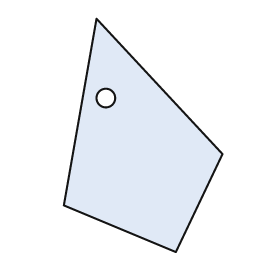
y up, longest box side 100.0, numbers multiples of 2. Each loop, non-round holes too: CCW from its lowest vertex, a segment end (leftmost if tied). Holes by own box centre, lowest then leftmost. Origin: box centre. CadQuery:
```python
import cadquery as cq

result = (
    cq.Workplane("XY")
    .moveTo(14.0, -50.0)
    .lineTo(34.0, -8.0)
    .lineTo(-20.0, 50.0)
    .lineTo(-34.0, -30.0)
    .close()
    .moveTo(-16.0, 16.0)
    .circle(4.0)
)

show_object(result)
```